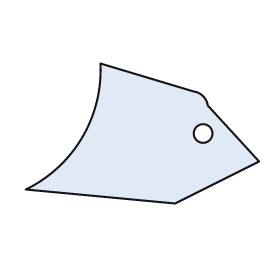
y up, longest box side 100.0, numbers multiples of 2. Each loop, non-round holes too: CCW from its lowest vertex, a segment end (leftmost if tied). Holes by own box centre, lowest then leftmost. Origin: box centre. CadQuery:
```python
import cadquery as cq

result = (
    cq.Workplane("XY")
    .moveTo(14.0, -30.0)
    .lineTo(50.0, -12.0)
    .lineTo(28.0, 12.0)
    .threePointArc((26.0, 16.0), (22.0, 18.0))
    .lineTo(-18.0, 30.0)
    .threePointArc((-26.0, -2.0), (-50.0, -24.0))
    .close()
    .moveTo(26.0, 0.0)
    .circle(4.0)
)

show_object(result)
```